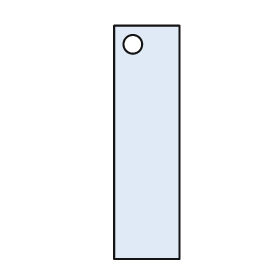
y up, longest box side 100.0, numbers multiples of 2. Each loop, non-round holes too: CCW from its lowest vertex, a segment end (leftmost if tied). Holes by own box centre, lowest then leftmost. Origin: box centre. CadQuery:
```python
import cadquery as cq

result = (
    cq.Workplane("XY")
    .moveTo(-14.0, -50.0)
    .lineTo(14.0, -50.0)
    .lineTo(14.0, 50.0)
    .lineTo(-14.0, 50.0)
    .close()
    .moveTo(-6.0, 42.0)
    .circle(4.0)
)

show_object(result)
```